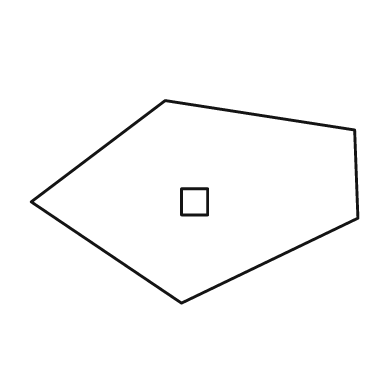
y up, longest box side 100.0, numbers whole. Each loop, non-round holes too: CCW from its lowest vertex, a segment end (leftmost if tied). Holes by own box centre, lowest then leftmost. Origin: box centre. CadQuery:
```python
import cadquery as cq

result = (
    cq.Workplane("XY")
    .moveTo(-4.0, -31.0)
    .lineTo(50.0, -5.0)
    .lineTo(49.0, 22.0)
    .lineTo(-9.0, 31.0)
    .lineTo(-50.0, 0.0)
    .close()
    .moveTo(-4.0, -4.0)
    .lineTo(4.0, -4.0)
    .lineTo(4.0, 4.0)
    .lineTo(-4.0, 4.0)
    .close()
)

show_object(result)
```